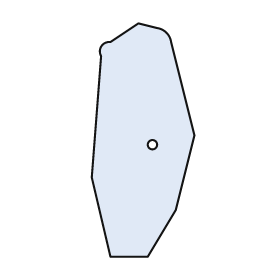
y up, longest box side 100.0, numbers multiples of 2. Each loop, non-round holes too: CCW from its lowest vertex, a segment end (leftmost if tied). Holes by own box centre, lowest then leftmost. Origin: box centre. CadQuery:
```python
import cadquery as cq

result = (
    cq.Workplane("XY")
    .moveTo(-14.0, -50.0)
    .lineTo(2.0, -50.0)
    .lineTo(14.0, -30.0)
    .lineTo(22.0, 2.0)
    .lineTo(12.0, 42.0)
    .threePointArc((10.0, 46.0), (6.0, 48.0))
    .lineTo(-2.0, 50.0)
    .lineTo(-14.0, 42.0)
    .threePointArc((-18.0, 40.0), (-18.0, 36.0))
    .lineTo(-22.0, -16.0)
    .close()
    .moveTo(4.0, -2.0)
    .circle(2.0)
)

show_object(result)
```